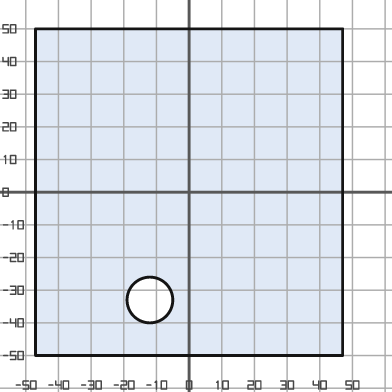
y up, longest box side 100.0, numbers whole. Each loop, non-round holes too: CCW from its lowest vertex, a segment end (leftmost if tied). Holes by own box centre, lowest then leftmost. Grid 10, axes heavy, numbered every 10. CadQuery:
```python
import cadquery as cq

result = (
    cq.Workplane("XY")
    .moveTo(-47.0, -50.0)
    .lineTo(47.0, -50.0)
    .lineTo(47.0, 50.0)
    .lineTo(-47.0, 50.0)
    .close()
    .moveTo(-12.0, -33.0)
    .circle(7.0)
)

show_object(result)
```